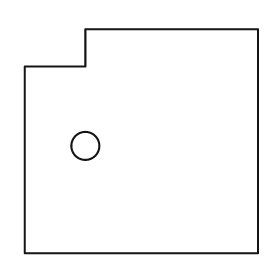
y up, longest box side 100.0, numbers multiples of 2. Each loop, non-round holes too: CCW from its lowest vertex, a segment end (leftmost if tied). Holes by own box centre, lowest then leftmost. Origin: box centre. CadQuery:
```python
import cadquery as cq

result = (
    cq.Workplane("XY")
    .moveTo(-50.0, -48.0)
    .lineTo(50.0, -48.0)
    .lineTo(50.0, 48.0)
    .lineTo(-24.0, 48.0)
    .lineTo(-24.0, 32.0)
    .lineTo(-50.0, 32.0)
    .close()
    .moveTo(-24.0, -2.0)
    .circle(6.0)
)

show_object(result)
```